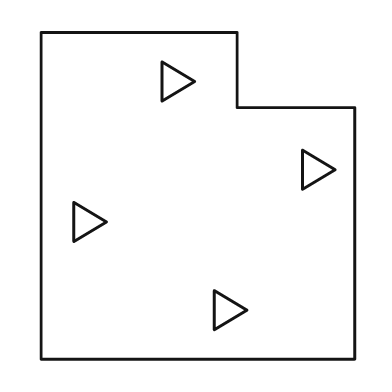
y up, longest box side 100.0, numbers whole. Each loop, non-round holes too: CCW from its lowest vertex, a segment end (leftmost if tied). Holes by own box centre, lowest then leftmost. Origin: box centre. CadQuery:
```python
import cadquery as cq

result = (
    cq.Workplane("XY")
    .moveTo(-48.0, -50.0)
    .lineTo(48.0, -50.0)
    .lineTo(48.0, 27.0)
    .lineTo(12.0, 27.0)
    .lineTo(12.0, 50.0)
    .lineTo(-48.0, 50.0)
    .close()
    .moveTo(5.0, -41.0)
    .lineTo(15.0, -35.0)
    .lineTo(5.0, -29.0)
    .close()
    .moveTo(-38.0, -14.0)
    .lineTo(-28.0, -8.0)
    .lineTo(-38.0, -2.0)
    .close()
    .moveTo(32.0, 2.0)
    .lineTo(42.0, 8.0)
    .lineTo(32.0, 14.0)
    .close()
    .moveTo(-11.0, 29.0)
    .lineTo(-1.0, 35.0)
    .lineTo(-11.0, 41.0)
    .close()
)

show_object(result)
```